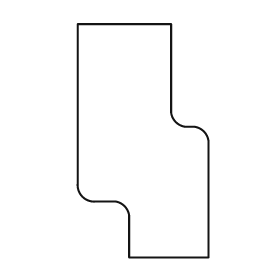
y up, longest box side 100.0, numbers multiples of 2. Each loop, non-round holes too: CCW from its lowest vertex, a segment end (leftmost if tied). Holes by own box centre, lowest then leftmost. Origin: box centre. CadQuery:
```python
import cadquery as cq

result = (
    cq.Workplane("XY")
    .moveTo(-6.0, -50.0)
    .lineTo(28.0, -50.0)
    .lineTo(28.0, 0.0)
    .threePointArc((26.0, 4.0), (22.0, 6.0))
    .lineTo(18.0, 6.0)
    .threePointArc((14.0, 8.0), (12.0, 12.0))
    .lineTo(12.0, 50.0)
    .lineTo(-28.0, 50.0)
    .lineTo(-28.0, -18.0)
    .threePointArc((-26.0, -24.0), (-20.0, -26.0))
    .lineTo(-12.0, -26.0)
    .threePointArc((-8.0, -28.0), (-6.0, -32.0))
    .close()
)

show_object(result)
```